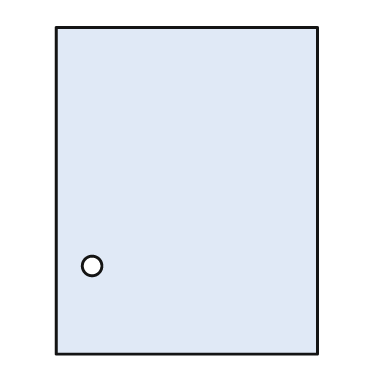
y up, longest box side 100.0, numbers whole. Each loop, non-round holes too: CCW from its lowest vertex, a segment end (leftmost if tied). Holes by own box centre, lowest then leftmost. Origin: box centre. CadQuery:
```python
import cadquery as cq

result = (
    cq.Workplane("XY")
    .moveTo(-40.0, -50.0)
    .lineTo(40.0, -50.0)
    .lineTo(40.0, 50.0)
    .lineTo(-40.0, 50.0)
    .close()
    .moveTo(-29.0, -23.0)
    .circle(3.0)
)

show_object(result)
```